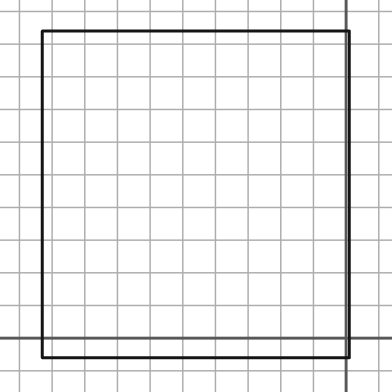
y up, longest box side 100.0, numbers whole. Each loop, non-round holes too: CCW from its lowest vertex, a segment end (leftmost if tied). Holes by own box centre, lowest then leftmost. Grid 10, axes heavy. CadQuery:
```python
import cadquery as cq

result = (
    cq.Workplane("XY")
    .moveTo(-93.0, -6.0)
    .lineTo(1.0, -6.0)
    .lineTo(1.0, 94.0)
    .lineTo(-93.0, 94.0)
    .close()
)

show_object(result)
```